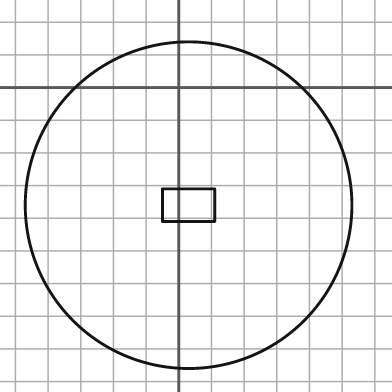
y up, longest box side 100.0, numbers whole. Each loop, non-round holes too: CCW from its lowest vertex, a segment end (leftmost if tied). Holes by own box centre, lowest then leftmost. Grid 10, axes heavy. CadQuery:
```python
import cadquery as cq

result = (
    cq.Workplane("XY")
    .moveTo(3.0, -36.0)
    .circle(50.0)
    .moveTo(-5.0, -41.0)
    .lineTo(11.0, -41.0)
    .lineTo(11.0, -31.0)
    .lineTo(-5.0, -31.0)
    .close()
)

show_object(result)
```